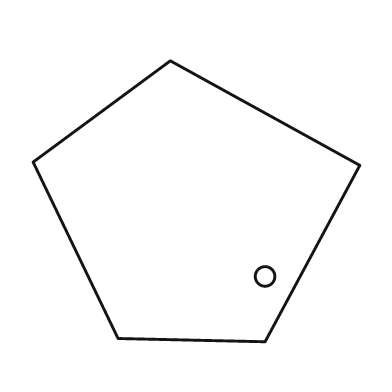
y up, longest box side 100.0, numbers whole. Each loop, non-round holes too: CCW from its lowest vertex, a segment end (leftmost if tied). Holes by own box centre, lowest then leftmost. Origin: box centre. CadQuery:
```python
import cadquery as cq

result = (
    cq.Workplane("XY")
    .moveTo(21.0, -43.0)
    .lineTo(50.0, 11.0)
    .lineTo(-8.0, 43.0)
    .lineTo(-50.0, 12.0)
    .lineTo(-24.0, -42.0)
    .close()
    .moveTo(21.0, -23.0)
    .circle(3.0)
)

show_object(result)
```